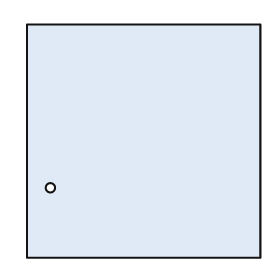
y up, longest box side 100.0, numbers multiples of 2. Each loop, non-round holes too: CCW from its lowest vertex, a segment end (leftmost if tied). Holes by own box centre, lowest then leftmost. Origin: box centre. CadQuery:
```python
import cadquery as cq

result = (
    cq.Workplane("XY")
    .moveTo(-50.0, -50.0)
    .lineTo(50.0, -50.0)
    .lineTo(50.0, 50.0)
    .lineTo(-50.0, 50.0)
    .close()
    .moveTo(-40.0, -20.0)
    .circle(2.0)
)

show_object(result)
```